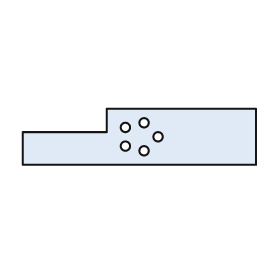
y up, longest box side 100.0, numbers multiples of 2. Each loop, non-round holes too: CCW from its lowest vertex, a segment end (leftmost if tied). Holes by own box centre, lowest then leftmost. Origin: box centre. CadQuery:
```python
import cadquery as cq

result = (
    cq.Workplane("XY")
    .moveTo(-50.0, -12.0)
    .lineTo(50.0, -12.0)
    .lineTo(50.0, 12.0)
    .lineTo(-14.0, 12.0)
    .lineTo(-14.0, 2.0)
    .lineTo(-50.0, 2.0)
    .close()
    .moveTo(2.0, -6.0)
    .circle(2.0)
    .moveTo(-6.0, -4.0)
    .circle(2.0)
    .moveTo(8.0, 0.0)
    .circle(2.0)
    .moveTo(-6.0, 4.0)
    .circle(2.0)
    .moveTo(2.0, 6.0)
    .circle(2.0)
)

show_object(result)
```